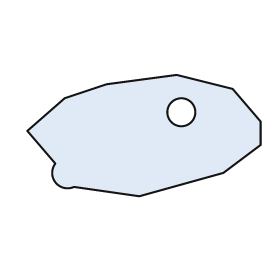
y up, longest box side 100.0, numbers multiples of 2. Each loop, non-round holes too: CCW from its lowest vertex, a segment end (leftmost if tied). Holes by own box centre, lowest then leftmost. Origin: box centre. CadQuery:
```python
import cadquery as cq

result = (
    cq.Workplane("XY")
    .moveTo(-2.0, -26.0)
    .lineTo(34.0, -16.0)
    .lineTo(50.0, -4.0)
    .lineTo(50.0, 6.0)
    .lineTo(38.0, 20.0)
    .lineTo(14.0, 26.0)
    .lineTo(-16.0, 22.0)
    .lineTo(-34.0, 16.0)
    .lineTo(-50.0, 2.0)
    .lineTo(-38.0, -12.0)
    .threePointArc((-38.0, -20.0), (-30.0, -22.0))
    .close()
    .moveTo(16.0, 10.0)
    .circle(6.0)
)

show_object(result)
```